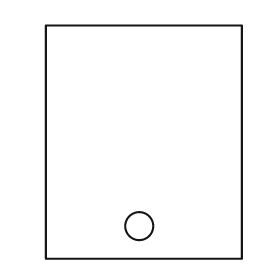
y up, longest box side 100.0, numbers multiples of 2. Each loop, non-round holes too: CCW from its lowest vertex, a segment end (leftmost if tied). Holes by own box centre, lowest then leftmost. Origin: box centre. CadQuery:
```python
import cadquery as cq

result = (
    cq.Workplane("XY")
    .moveTo(-42.0, -50.0)
    .lineTo(42.0, -50.0)
    .lineTo(42.0, 50.0)
    .lineTo(-42.0, 50.0)
    .close()
    .moveTo(-2.0, -36.0)
    .circle(6.0)
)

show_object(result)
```